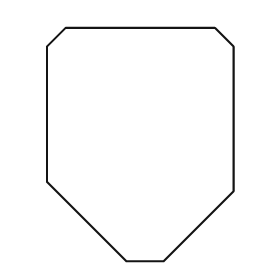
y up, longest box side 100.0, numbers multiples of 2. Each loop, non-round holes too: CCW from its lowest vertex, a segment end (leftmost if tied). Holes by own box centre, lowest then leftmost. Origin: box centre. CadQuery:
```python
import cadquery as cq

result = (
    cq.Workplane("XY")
    .moveTo(-6.0, -50.0)
    .lineTo(10.0, -50.0)
    .lineTo(40.0, -20.0)
    .lineTo(40.0, 42.0)
    .lineTo(32.0, 50.0)
    .lineTo(-32.0, 50.0)
    .lineTo(-40.0, 42.0)
    .lineTo(-40.0, -16.0)
    .close()
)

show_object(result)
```